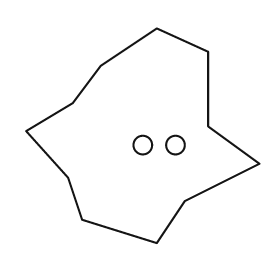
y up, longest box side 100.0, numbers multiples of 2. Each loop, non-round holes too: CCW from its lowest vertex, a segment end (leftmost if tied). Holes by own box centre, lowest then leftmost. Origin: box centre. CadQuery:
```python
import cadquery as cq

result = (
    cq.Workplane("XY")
    .moveTo(6.0, -46.0)
    .lineTo(18.0, -28.0)
    .lineTo(50.0, -12.0)
    .lineTo(28.0, 4.0)
    .lineTo(28.0, 36.0)
    .lineTo(6.0, 46.0)
    .lineTo(-18.0, 30.0)
    .lineTo(-30.0, 14.0)
    .lineTo(-50.0, 2.0)
    .lineTo(-32.0, -18.0)
    .lineTo(-26.0, -36.0)
    .close()
    .moveTo(0.0, -4.0)
    .circle(4.0)
    .moveTo(14.0, -4.0)
    .circle(4.0)
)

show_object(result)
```